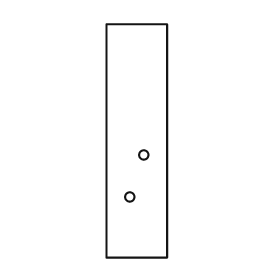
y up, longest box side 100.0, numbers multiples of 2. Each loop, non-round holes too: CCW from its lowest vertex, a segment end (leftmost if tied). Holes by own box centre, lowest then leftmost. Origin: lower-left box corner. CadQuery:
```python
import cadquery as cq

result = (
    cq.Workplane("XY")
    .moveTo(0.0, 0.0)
    .lineTo(26.0, 0.0)
    .lineTo(26.0, 100.0)
    .lineTo(0.0, 100.0)
    .close()
    .moveTo(10.0, 26.0)
    .circle(2.0)
    .moveTo(16.0, 44.0)
    .circle(2.0)
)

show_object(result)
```